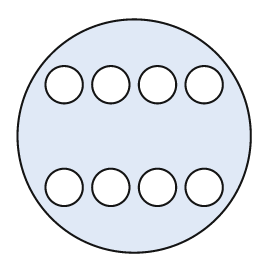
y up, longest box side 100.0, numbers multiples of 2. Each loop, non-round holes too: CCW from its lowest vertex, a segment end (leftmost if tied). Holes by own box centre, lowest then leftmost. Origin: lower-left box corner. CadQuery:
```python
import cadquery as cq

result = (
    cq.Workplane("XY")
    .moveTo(50.0, 50.0)
    .circle(50.0)
    .moveTo(20.0, 28.0)
    .circle(8.0)
    .moveTo(40.0, 28.0)
    .circle(8.0)
    .moveTo(60.0, 28.0)
    .circle(8.0)
    .moveTo(80.0, 28.0)
    .circle(8.0)
    .moveTo(20.0, 72.0)
    .circle(8.0)
    .moveTo(40.0, 72.0)
    .circle(8.0)
    .moveTo(60.0, 72.0)
    .circle(8.0)
    .moveTo(80.0, 72.0)
    .circle(8.0)
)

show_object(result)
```